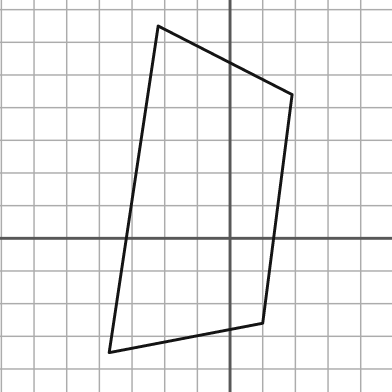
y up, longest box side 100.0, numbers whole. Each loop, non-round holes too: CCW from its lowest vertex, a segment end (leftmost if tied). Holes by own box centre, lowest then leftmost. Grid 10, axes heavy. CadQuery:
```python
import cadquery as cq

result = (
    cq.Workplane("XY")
    .moveTo(-37.0, -35.0)
    .lineTo(10.0, -26.0)
    .lineTo(19.0, 44.0)
    .lineTo(-22.0, 65.0)
    .close()
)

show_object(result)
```